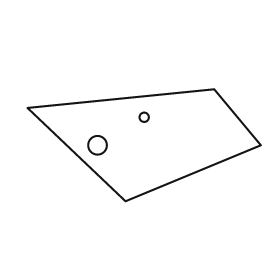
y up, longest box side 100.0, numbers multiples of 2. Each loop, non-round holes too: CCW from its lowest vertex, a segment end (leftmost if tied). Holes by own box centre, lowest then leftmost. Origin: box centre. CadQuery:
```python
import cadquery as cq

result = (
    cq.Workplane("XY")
    .moveTo(-8.0, -24.0)
    .lineTo(50.0, 0.0)
    .lineTo(30.0, 24.0)
    .lineTo(-50.0, 16.0)
    .close()
    .moveTo(-20.0, 0.0)
    .circle(4.0)
    .moveTo(0.0, 12.0)
    .circle(2.0)
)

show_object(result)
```